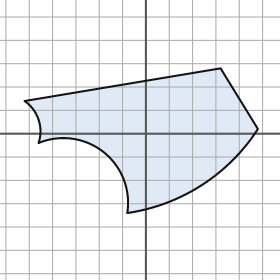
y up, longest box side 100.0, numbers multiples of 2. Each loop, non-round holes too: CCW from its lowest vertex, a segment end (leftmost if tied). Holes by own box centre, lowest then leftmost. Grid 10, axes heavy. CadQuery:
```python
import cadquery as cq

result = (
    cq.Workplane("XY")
    .moveTo(-8.0, -34.0)
    .threePointArc((24.0, -22.0), (48.0, 2.0))
    .lineTo(32.0, 28.0)
    .lineTo(-52.0, 14.0)
    .threePointArc((-46.0, 6.0), (-46.0, -4.0))
    .threePointArc((-18.0, -8.0), (-8.0, -34.0))
    .close()
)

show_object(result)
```